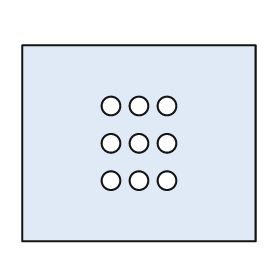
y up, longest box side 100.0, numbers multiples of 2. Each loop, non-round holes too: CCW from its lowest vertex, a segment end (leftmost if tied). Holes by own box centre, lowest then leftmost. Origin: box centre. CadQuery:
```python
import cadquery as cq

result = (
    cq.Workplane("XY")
    .moveTo(-50.0, -42.0)
    .lineTo(50.0, -42.0)
    .lineTo(50.0, 42.0)
    .lineTo(-50.0, 42.0)
    .close()
    .moveTo(-12.0, -16.0)
    .circle(4.0)
    .moveTo(0.0, -16.0)
    .circle(4.0)
    .moveTo(12.0, -16.0)
    .circle(4.0)
    .moveTo(-12.0, 0.0)
    .circle(4.0)
    .moveTo(0.0, 0.0)
    .circle(4.0)
    .moveTo(12.0, 0.0)
    .circle(4.0)
    .moveTo(-12.0, 16.0)
    .circle(4.0)
    .moveTo(0.0, 16.0)
    .circle(4.0)
    .moveTo(12.0, 16.0)
    .circle(4.0)
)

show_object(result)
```